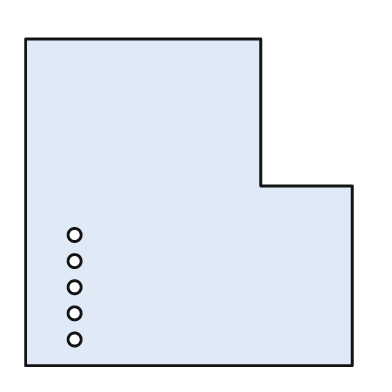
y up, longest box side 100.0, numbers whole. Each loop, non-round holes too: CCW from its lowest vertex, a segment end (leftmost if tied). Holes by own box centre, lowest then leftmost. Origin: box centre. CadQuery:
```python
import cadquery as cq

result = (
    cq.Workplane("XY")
    .moveTo(-50.0, -50.0)
    .lineTo(50.0, -50.0)
    .lineTo(50.0, 5.0)
    .lineTo(22.0, 5.0)
    .lineTo(22.0, 50.0)
    .lineTo(-50.0, 50.0)
    .close()
    .moveTo(-35.0, -42.0)
    .circle(2.0)
    .moveTo(-35.0, -34.0)
    .circle(2.0)
    .moveTo(-35.0, -26.0)
    .circle(2.0)
    .moveTo(-35.0, -18.0)
    .circle(2.0)
    .moveTo(-35.0, -10.0)
    .circle(2.0)
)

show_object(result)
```